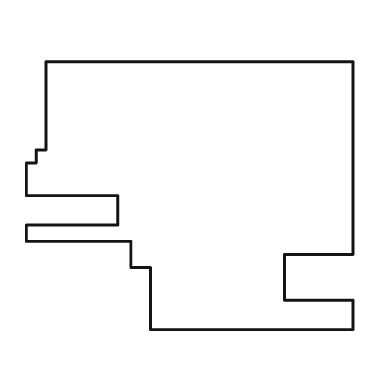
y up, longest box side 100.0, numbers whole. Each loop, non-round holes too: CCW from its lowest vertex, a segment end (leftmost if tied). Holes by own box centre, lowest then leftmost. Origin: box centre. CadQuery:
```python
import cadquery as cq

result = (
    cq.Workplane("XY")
    .moveTo(-12.0, -41.0)
    .lineTo(50.0, -41.0)
    .lineTo(50.0, -32.0)
    .lineTo(29.0, -32.0)
    .lineTo(29.0, -18.0)
    .lineTo(50.0, -18.0)
    .lineTo(50.0, 41.0)
    .lineTo(-44.0, 41.0)
    .lineTo(-44.0, 14.0)
    .lineTo(-47.0, 14.0)
    .lineTo(-47.0, 10.0)
    .lineTo(-50.0, 10.0)
    .lineTo(-50.0, 0.0)
    .lineTo(-22.0, 0.0)
    .lineTo(-22.0, -9.0)
    .lineTo(-50.0, -9.0)
    .lineTo(-50.0, -14.0)
    .lineTo(-18.0, -14.0)
    .lineTo(-18.0, -22.0)
    .lineTo(-12.0, -22.0)
    .close()
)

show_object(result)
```